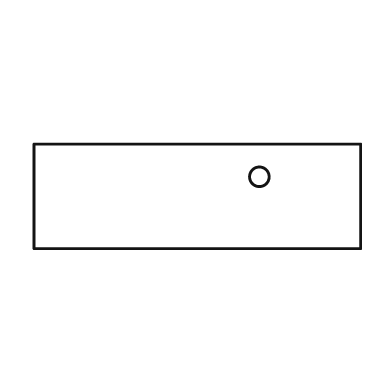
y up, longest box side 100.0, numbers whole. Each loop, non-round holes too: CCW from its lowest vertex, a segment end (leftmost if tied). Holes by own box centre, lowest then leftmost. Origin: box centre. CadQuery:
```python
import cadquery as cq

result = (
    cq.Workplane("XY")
    .moveTo(-50.0, -16.0)
    .lineTo(50.0, -16.0)
    .lineTo(50.0, 16.0)
    .lineTo(-50.0, 16.0)
    .close()
    .moveTo(19.0, 6.0)
    .circle(3.0)
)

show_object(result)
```